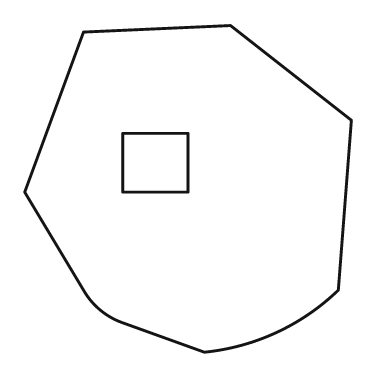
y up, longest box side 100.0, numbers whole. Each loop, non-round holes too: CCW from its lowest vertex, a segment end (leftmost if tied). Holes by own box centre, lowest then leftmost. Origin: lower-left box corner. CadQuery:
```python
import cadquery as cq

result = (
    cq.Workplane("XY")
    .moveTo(55.0, 0.0)
    .threePointArc((77.0, 6.0), (96.0, 19.0))
    .lineTo(100.0, 71.0)
    .lineTo(63.0, 100.0)
    .lineTo(18.0, 98.0)
    .lineTo(0.0, 49.0)
    .lineTo(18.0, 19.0)
    .threePointArc((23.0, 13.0), (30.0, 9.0))
    .close()
    .moveTo(30.0, 49.0)
    .lineTo(50.0, 49.0)
    .lineTo(50.0, 67.0)
    .lineTo(30.0, 67.0)
    .close()
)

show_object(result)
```